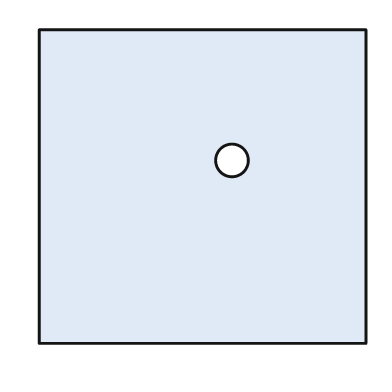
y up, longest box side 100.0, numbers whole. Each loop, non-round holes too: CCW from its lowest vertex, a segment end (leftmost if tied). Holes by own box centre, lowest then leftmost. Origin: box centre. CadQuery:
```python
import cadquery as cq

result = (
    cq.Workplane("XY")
    .moveTo(-50.0, -48.0)
    .lineTo(50.0, -48.0)
    .lineTo(50.0, 48.0)
    .lineTo(-50.0, 48.0)
    .close()
    .moveTo(9.0, 8.0)
    .circle(5.0)
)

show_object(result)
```